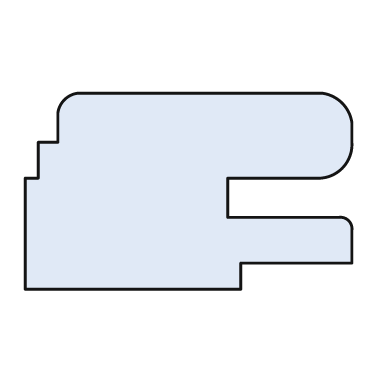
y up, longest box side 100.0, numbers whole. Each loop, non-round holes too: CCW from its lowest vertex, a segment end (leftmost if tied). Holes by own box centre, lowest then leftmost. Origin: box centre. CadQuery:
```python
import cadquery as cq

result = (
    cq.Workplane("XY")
    .moveTo(-50.0, -30.0)
    .lineTo(16.0, -30.0)
    .lineTo(16.0, -22.0)
    .lineTo(50.0, -22.0)
    .lineTo(50.0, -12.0)
    .threePointArc((49.0, -9.0), (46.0, -8.0))
    .lineTo(12.0, -8.0)
    .lineTo(12.0, 4.0)
    .lineTo(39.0, 4.0)
    .threePointArc((47.0, 7.0), (50.0, 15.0))
    .lineTo(50.0, 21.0)
    .threePointArc((47.0, 27.0), (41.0, 30.0))
    .lineTo(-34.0, 30.0)
    .threePointArc((-38.0, 28.0), (-40.0, 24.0))
    .lineTo(-40.0, 15.0)
    .lineTo(-46.0, 15.0)
    .lineTo(-46.0, 4.0)
    .lineTo(-50.0, 4.0)
    .close()
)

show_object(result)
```